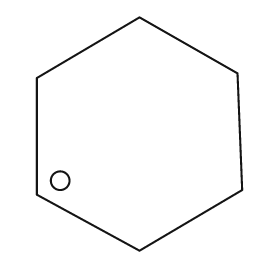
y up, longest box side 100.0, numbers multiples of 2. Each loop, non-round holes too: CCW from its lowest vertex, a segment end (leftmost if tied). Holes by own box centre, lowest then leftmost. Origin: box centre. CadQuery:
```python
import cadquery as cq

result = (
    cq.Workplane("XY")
    .moveTo(0.0, -50.0)
    .lineTo(44.0, -24.0)
    .lineTo(42.0, 26.0)
    .lineTo(0.0, 50.0)
    .lineTo(-44.0, 24.0)
    .lineTo(-44.0, -26.0)
    .close()
    .moveTo(-34.0, -20.0)
    .circle(4.0)
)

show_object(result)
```